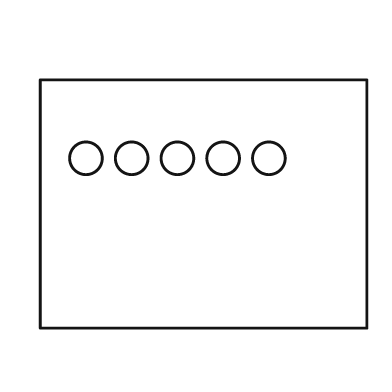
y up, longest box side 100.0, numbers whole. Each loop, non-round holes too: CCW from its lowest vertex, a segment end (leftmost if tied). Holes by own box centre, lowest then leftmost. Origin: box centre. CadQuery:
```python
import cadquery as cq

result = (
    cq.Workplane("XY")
    .moveTo(-50.0, -38.0)
    .lineTo(50.0, -38.0)
    .lineTo(50.0, 38.0)
    .lineTo(-50.0, 38.0)
    .close()
    .moveTo(-36.0, 14.0)
    .circle(5.0)
    .moveTo(-22.0, 14.0)
    .circle(5.0)
    .moveTo(-8.0, 14.0)
    .circle(5.0)
    .moveTo(6.0, 14.0)
    .circle(5.0)
    .moveTo(20.0, 14.0)
    .circle(5.0)
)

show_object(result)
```